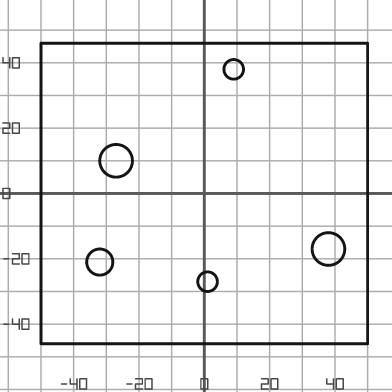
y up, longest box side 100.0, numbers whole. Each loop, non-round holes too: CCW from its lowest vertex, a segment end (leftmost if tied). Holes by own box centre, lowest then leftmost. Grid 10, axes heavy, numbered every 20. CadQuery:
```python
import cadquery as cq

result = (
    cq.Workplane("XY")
    .moveTo(-50.0, -46.0)
    .lineTo(50.0, -46.0)
    .lineTo(50.0, 46.0)
    .lineTo(-50.0, 46.0)
    .close()
    .moveTo(1.0, -27.0)
    .circle(3.0)
    .moveTo(-32.0, -21.0)
    .circle(4.0)
    .moveTo(38.0, -17.0)
    .circle(5.0)
    .moveTo(-27.0, 10.0)
    .circle(5.0)
    .moveTo(9.0, 38.0)
    .circle(3.0)
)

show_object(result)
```